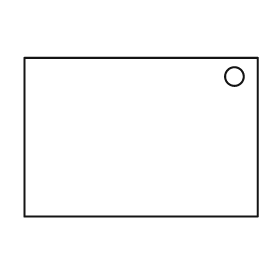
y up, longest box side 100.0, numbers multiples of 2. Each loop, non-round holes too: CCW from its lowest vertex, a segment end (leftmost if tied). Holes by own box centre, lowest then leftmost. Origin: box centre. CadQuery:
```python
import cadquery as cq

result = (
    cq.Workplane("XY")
    .moveTo(-50.0, -34.0)
    .lineTo(50.0, -34.0)
    .lineTo(50.0, 34.0)
    .lineTo(-50.0, 34.0)
    .close()
    .moveTo(40.0, 26.0)
    .circle(4.0)
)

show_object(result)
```